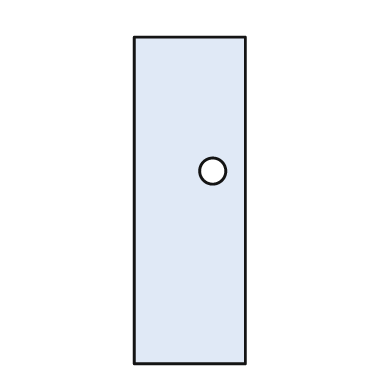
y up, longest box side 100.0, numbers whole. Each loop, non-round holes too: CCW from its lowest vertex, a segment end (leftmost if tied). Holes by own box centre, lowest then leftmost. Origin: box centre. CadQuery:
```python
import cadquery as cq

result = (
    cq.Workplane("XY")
    .moveTo(-17.0, -50.0)
    .lineTo(17.0, -50.0)
    .lineTo(17.0, 50.0)
    .lineTo(-17.0, 50.0)
    .close()
    .moveTo(7.0, 9.0)
    .circle(4.0)
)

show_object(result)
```